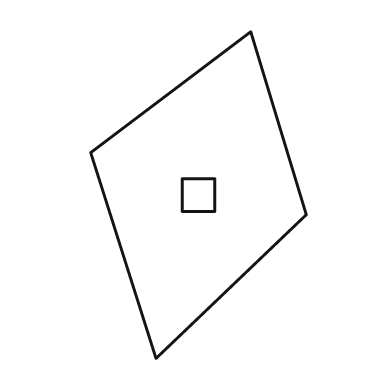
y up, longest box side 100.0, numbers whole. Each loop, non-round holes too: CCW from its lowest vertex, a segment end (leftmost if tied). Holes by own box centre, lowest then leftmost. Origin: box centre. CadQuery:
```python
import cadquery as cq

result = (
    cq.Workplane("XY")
    .moveTo(-13.0, -50.0)
    .lineTo(33.0, -6.0)
    .lineTo(16.0, 50.0)
    .lineTo(-33.0, 13.0)
    .close()
    .moveTo(-5.0, -5.0)
    .lineTo(5.0, -5.0)
    .lineTo(5.0, 5.0)
    .lineTo(-5.0, 5.0)
    .close()
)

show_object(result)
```